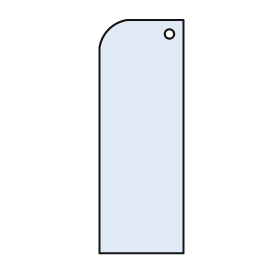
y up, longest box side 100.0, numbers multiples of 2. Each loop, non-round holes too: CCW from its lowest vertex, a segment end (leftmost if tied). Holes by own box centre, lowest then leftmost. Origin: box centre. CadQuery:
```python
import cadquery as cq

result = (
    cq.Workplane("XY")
    .moveTo(-18.0, -50.0)
    .lineTo(18.0, -50.0)
    .lineTo(18.0, 50.0)
    .lineTo(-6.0, 50.0)
    .threePointArc((-14.0, 46.0), (-18.0, 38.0))
    .close()
    .moveTo(12.0, 44.0)
    .circle(2.0)
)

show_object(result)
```